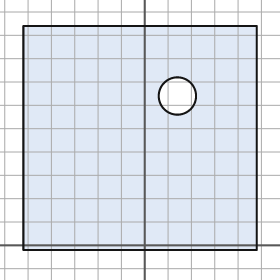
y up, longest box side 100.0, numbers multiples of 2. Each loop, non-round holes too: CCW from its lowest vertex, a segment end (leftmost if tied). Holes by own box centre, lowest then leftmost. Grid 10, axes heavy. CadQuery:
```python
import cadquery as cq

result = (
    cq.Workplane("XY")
    .moveTo(-52.0, -2.0)
    .lineTo(48.0, -2.0)
    .lineTo(48.0, 94.0)
    .lineTo(-52.0, 94.0)
    .close()
    .moveTo(14.0, 64.0)
    .circle(8.0)
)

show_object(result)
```